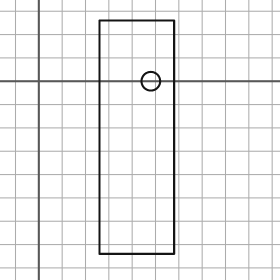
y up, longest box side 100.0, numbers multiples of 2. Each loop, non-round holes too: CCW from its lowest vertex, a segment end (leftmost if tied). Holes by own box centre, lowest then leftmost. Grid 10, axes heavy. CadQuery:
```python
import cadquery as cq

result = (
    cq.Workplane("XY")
    .moveTo(26.0, -74.0)
    .lineTo(58.0, -74.0)
    .lineTo(58.0, 26.0)
    .lineTo(26.0, 26.0)
    .close()
    .moveTo(48.0, 0.0)
    .circle(4.0)
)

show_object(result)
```